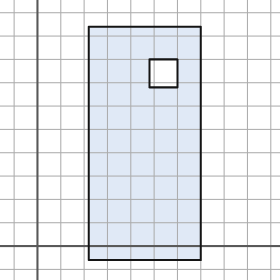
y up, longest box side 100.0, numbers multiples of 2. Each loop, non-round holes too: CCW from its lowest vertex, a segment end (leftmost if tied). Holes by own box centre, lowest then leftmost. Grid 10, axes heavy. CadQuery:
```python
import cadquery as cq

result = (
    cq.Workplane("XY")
    .moveTo(22.0, -6.0)
    .lineTo(70.0, -6.0)
    .lineTo(70.0, 94.0)
    .lineTo(22.0, 94.0)
    .close()
    .moveTo(48.0, 68.0)
    .lineTo(60.0, 68.0)
    .lineTo(60.0, 80.0)
    .lineTo(48.0, 80.0)
    .close()
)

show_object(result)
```